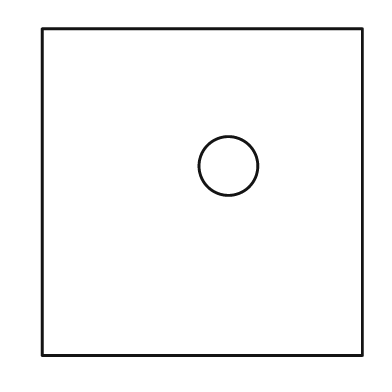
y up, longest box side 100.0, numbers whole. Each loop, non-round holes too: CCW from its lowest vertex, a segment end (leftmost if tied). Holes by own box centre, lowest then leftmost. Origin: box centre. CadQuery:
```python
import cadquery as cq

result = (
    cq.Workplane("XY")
    .moveTo(-49.0, -50.0)
    .lineTo(49.0, -50.0)
    .lineTo(49.0, 50.0)
    .lineTo(-49.0, 50.0)
    .close()
    .moveTo(8.0, 8.0)
    .circle(9.0)
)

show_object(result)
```